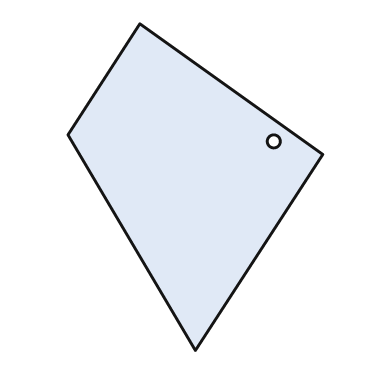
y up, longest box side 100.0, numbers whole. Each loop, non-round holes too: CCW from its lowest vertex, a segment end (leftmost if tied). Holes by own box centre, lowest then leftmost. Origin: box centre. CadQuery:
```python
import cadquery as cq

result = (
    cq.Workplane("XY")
    .moveTo(0.0, -50.0)
    .lineTo(39.0, 10.0)
    .lineTo(-17.0, 50.0)
    .lineTo(-39.0, 16.0)
    .close()
    .moveTo(24.0, 14.0)
    .circle(2.0)
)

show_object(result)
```